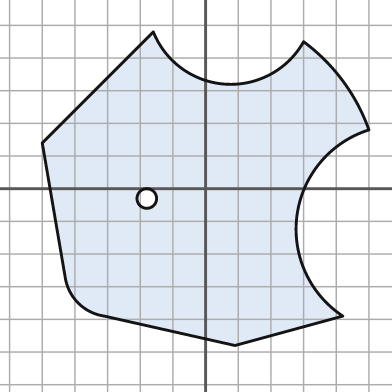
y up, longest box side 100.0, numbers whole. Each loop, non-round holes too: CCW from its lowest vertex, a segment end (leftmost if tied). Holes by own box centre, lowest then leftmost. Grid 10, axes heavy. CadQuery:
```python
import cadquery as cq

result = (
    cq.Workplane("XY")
    .moveTo(9.0, -48.0)
    .lineTo(42.0, -39.0)
    .threePointArc((28.0, -8.0), (50.0, 18.0))
    .threePointArc((42.0, 33.0), (30.0, 45.0))
    .threePointArc((6.0, 32.0), (-16.0, 48.0))
    .lineTo(-50.0, 14.0)
    .lineTo(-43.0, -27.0)
    .threePointArc((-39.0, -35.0), (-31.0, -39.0))
    .close()
    .moveTo(-18.0, -3.0)
    .circle(3.0)
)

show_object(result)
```